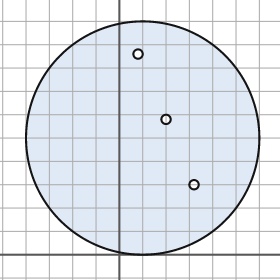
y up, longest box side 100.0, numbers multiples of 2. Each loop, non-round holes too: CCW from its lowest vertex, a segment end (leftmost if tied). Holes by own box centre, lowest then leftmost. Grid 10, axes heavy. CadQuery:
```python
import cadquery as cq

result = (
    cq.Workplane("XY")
    .moveTo(10.0, 50.0)
    .circle(50.0)
    .moveTo(32.0, 30.0)
    .circle(2.0)
    .moveTo(20.0, 58.0)
    .circle(2.0)
    .moveTo(8.0, 86.0)
    .circle(2.0)
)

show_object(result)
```